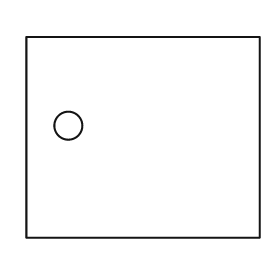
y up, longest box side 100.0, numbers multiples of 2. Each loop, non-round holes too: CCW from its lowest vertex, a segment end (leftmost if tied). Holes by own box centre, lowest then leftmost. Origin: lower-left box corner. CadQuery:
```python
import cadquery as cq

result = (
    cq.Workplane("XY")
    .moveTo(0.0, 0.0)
    .lineTo(100.0, 0.0)
    .lineTo(100.0, 86.0)
    .lineTo(0.0, 86.0)
    .close()
    .moveTo(18.0, 48.0)
    .circle(6.0)
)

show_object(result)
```